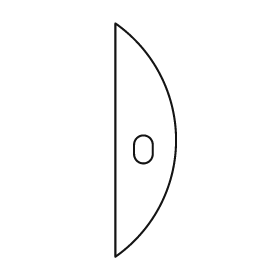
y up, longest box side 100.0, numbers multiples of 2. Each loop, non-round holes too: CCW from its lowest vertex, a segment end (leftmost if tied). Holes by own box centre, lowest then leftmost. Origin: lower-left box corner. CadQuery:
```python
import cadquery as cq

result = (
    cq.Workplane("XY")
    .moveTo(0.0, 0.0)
    .threePointArc((26.0, 50.0), (0.0, 100.0))
    .close()
    .moveTo(8.0, 44.0)
    .threePointArc((12.0, 40.0), (16.0, 44.0))
    .lineTo(16.0, 48.0)
    .threePointArc((12.0, 52.0), (8.0, 48.0))
    .close()
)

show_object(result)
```